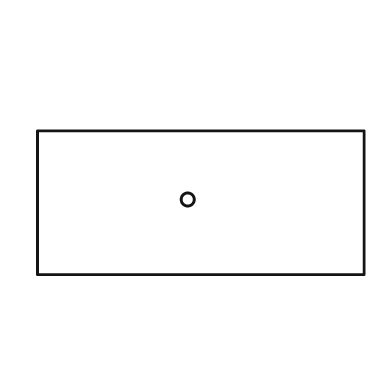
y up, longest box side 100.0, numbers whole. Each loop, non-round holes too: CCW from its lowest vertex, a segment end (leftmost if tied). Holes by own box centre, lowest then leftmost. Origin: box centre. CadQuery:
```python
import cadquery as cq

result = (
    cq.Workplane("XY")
    .moveTo(-50.0, -22.0)
    .lineTo(50.0, -22.0)
    .lineTo(50.0, 22.0)
    .lineTo(-50.0, 22.0)
    .close()
    .moveTo(-4.0, 1.0)
    .circle(2.0)
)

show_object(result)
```